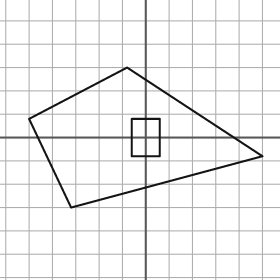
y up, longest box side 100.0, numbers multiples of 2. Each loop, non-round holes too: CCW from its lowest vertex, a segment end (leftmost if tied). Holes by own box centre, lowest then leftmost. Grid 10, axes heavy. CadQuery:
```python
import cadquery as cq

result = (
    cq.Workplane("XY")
    .moveTo(-32.0, -30.0)
    .lineTo(50.0, -8.0)
    .lineTo(-8.0, 30.0)
    .lineTo(-50.0, 8.0)
    .close()
    .moveTo(-6.0, -8.0)
    .lineTo(6.0, -8.0)
    .lineTo(6.0, 8.0)
    .lineTo(-6.0, 8.0)
    .close()
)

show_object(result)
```